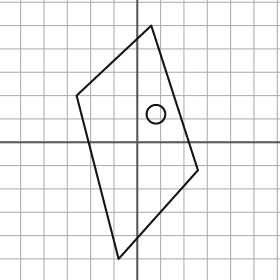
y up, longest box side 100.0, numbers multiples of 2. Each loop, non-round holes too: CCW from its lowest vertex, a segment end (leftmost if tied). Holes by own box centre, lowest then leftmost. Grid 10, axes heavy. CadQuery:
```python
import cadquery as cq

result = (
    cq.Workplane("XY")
    .moveTo(-8.0, -50.0)
    .lineTo(26.0, -12.0)
    .lineTo(6.0, 50.0)
    .lineTo(-26.0, 20.0)
    .close()
    .moveTo(8.0, 12.0)
    .circle(4.0)
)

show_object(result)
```